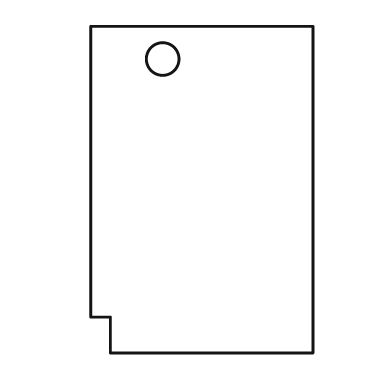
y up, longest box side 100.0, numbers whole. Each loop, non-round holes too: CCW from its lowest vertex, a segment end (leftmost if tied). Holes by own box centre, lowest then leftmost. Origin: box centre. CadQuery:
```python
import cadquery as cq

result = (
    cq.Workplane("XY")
    .moveTo(-28.0, -50.0)
    .lineTo(34.0, -50.0)
    .lineTo(34.0, 50.0)
    .lineTo(-34.0, 50.0)
    .lineTo(-34.0, -39.0)
    .lineTo(-28.0, -39.0)
    .close()
    .moveTo(-12.0, 40.0)
    .circle(5.0)
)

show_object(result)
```